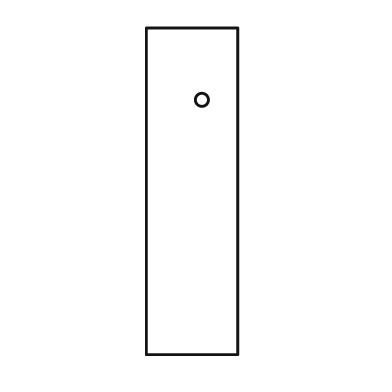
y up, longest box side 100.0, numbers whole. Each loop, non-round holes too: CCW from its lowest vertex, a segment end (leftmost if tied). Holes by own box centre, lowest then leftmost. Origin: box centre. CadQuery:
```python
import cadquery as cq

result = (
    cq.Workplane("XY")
    .moveTo(-14.0, -50.0)
    .lineTo(14.0, -50.0)
    .lineTo(14.0, 50.0)
    .lineTo(-14.0, 50.0)
    .close()
    .moveTo(3.0, 28.0)
    .circle(2.0)
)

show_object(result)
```